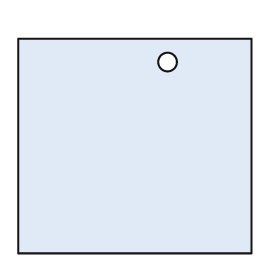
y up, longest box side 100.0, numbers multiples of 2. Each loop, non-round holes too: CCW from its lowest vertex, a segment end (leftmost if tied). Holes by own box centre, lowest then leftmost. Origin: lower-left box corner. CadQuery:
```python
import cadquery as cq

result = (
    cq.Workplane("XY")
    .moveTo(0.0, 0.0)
    .lineTo(100.0, 0.0)
    .lineTo(100.0, 92.0)
    .lineTo(0.0, 92.0)
    .close()
    .moveTo(64.0, 82.0)
    .circle(4.0)
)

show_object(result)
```